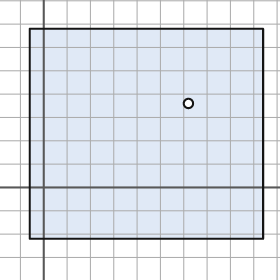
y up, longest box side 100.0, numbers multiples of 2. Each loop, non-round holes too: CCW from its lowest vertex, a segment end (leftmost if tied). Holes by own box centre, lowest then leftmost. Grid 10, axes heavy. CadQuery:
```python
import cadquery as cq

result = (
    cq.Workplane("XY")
    .moveTo(-6.0, -22.0)
    .lineTo(94.0, -22.0)
    .lineTo(94.0, 68.0)
    .lineTo(-6.0, 68.0)
    .close()
    .moveTo(62.0, 36.0)
    .circle(2.0)
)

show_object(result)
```